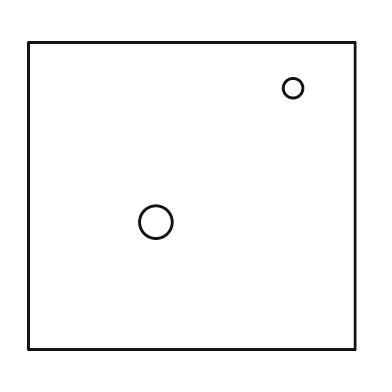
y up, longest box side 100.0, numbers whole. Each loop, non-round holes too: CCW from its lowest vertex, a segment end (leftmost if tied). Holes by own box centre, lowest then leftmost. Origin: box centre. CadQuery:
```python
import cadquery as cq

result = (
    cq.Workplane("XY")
    .moveTo(-50.0, -47.0)
    .lineTo(50.0, -47.0)
    .lineTo(50.0, 47.0)
    .lineTo(-50.0, 47.0)
    .close()
    .moveTo(-11.0, -8.0)
    .circle(5.0)
    .moveTo(31.0, 33.0)
    .circle(3.0)
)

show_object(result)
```